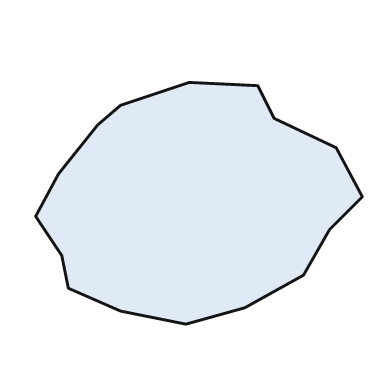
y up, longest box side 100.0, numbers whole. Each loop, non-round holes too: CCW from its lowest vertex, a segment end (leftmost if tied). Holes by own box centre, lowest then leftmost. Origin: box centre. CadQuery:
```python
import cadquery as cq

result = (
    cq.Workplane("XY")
    .moveTo(-4.0, -37.0)
    .lineTo(14.0, -32.0)
    .lineTo(32.0, -22.0)
    .lineTo(40.0, -8.0)
    .lineTo(50.0, 2.0)
    .lineTo(42.0, 17.0)
    .lineTo(23.0, 26.0)
    .lineTo(18.0, 36.0)
    .lineTo(-3.0, 37.0)
    .lineTo(-24.0, 30.0)
    .lineTo(-31.0, 24.0)
    .lineTo(-43.0, 9.0)
    .lineTo(-50.0, -4.0)
    .lineTo(-42.0, -16.0)
    .lineTo(-40.0, -26.0)
    .lineTo(-24.0, -33.0)
    .close()
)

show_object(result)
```